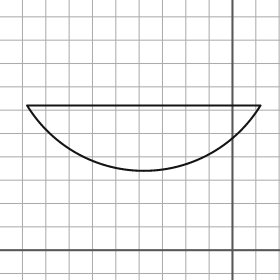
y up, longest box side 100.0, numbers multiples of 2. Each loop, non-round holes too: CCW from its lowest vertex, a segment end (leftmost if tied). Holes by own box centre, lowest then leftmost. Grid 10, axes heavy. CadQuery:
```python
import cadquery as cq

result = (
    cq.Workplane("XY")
    .moveTo(-88.0, 62.0)
    .threePointArc((-38.0, 34.0), (12.0, 62.0))
    .close()
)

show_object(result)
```